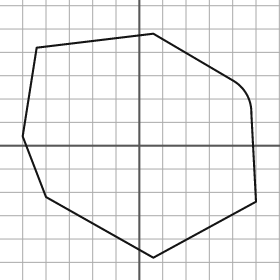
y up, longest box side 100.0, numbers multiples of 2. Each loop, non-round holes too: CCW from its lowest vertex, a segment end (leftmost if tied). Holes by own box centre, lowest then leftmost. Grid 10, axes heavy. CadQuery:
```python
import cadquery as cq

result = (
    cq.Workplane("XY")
    .moveTo(6.0, -48.0)
    .lineTo(50.0, -24.0)
    .lineTo(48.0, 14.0)
    .threePointArc((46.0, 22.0), (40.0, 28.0))
    .lineTo(6.0, 48.0)
    .lineTo(-44.0, 42.0)
    .lineTo(-50.0, 4.0)
    .lineTo(-40.0, -22.0)
    .close()
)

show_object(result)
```